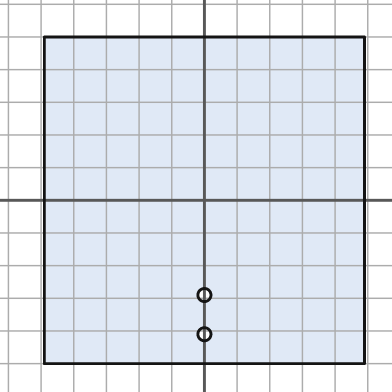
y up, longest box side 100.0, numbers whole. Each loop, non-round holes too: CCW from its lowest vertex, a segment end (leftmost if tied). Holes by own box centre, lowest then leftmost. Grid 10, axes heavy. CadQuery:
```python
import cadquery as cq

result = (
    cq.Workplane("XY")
    .moveTo(-49.0, -50.0)
    .lineTo(49.0, -50.0)
    .lineTo(49.0, 50.0)
    .lineTo(-49.0, 50.0)
    .close()
    .moveTo(0.0, -41.0)
    .circle(2.0)
    .moveTo(0.0, -29.0)
    .circle(2.0)
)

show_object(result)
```